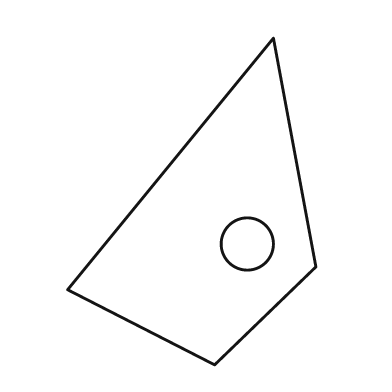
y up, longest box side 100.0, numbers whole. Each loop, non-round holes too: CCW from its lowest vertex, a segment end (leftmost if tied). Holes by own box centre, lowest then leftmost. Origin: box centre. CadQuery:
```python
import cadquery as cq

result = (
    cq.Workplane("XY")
    .moveTo(7.0, -50.0)
    .lineTo(38.0, -20.0)
    .lineTo(25.0, 50.0)
    .lineTo(-38.0, -27.0)
    .close()
    .moveTo(17.0, -13.0)
    .circle(8.0)
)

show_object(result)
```